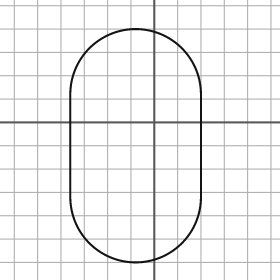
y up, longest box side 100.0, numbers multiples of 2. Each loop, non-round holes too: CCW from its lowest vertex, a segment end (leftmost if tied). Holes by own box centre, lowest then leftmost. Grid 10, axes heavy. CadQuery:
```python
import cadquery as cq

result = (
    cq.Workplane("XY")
    .moveTo(-36.0, -32.0)
    .threePointArc((-8.0, -60.0), (20.0, -32.0))
    .lineTo(20.0, 12.0)
    .threePointArc((-8.0, 40.0), (-36.0, 12.0))
    .close()
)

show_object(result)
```